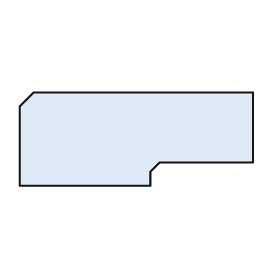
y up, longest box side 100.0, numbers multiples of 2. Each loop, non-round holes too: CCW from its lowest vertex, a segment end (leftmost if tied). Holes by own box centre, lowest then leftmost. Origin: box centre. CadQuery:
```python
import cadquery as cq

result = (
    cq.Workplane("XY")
    .moveTo(-50.0, -20.0)
    .lineTo(6.0, -20.0)
    .lineTo(6.0, -14.0)
    .lineTo(10.0, -10.0)
    .lineTo(50.0, -10.0)
    .lineTo(50.0, 20.0)
    .lineTo(-44.0, 20.0)
    .lineTo(-50.0, 14.0)
    .close()
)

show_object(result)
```